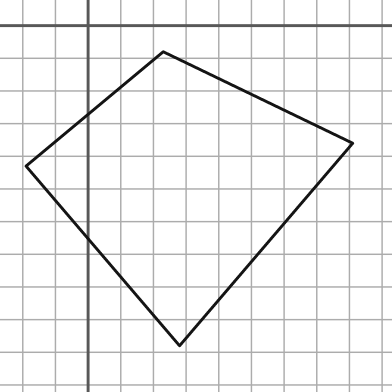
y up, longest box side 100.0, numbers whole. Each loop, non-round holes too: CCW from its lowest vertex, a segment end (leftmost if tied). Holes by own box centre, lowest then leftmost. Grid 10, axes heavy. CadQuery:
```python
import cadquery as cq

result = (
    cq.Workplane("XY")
    .moveTo(28.0, -98.0)
    .lineTo(81.0, -36.0)
    .lineTo(23.0, -8.0)
    .lineTo(-19.0, -43.0)
    .close()
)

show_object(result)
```